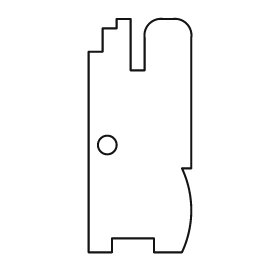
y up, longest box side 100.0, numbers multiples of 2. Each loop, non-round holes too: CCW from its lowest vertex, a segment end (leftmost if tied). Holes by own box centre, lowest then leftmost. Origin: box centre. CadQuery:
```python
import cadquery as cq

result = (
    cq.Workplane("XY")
    .moveTo(-22.0, -50.0)
    .lineTo(-12.0, -50.0)
    .lineTo(-12.0, -44.0)
    .lineTo(6.0, -44.0)
    .lineTo(6.0, -50.0)
    .lineTo(18.0, -50.0)
    .threePointArc((22.0, -32.0), (18.0, -14.0))
    .lineTo(22.0, -14.0)
    .lineTo(22.0, 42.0)
    .threePointArc((20.0, 48.0), (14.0, 50.0))
    .lineTo(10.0, 50.0)
    .threePointArc((4.0, 48.0), (2.0, 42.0))
    .lineTo(2.0, 28.0)
    .lineTo(-4.0, 28.0)
    .lineTo(-4.0, 50.0)
    .lineTo(-10.0, 50.0)
    .lineTo(-10.0, 46.0)
    .lineTo(-16.0, 46.0)
    .lineTo(-16.0, 36.0)
    .lineTo(-22.0, 36.0)
    .close()
    .moveTo(-14.0, -4.0)
    .circle(4.0)
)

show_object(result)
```